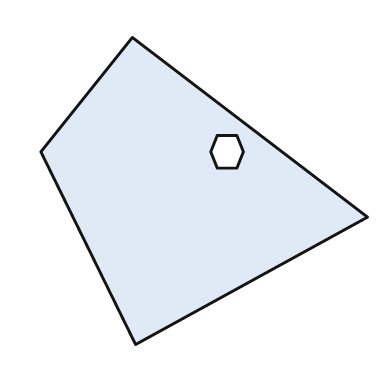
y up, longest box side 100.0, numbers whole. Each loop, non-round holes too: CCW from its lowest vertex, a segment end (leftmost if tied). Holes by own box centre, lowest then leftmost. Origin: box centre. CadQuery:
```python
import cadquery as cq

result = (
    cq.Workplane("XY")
    .moveTo(-21.0, -47.0)
    .lineTo(50.0, -8.0)
    .lineTo(-22.0, 47.0)
    .lineTo(-50.0, 12.0)
    .close()
    .moveTo(4.0, 7.0)
    .lineTo(10.0, 7.0)
    .lineTo(12.0, 12.0)
    .lineTo(10.0, 17.0)
    .lineTo(4.0, 17.0)
    .lineTo(2.0, 12.0)
    .close()
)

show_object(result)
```